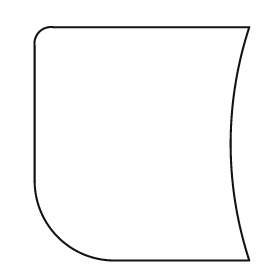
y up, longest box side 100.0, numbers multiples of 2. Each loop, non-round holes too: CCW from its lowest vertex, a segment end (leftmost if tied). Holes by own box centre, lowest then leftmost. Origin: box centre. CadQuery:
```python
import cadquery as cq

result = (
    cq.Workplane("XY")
    .moveTo(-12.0, -50.0)
    .lineTo(46.0, -50.0)
    .threePointArc((38.0, 0.0), (46.0, 50.0))
    .lineTo(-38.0, 50.0)
    .threePointArc((-44.0, 48.0), (-46.0, 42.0))
    .lineTo(-46.0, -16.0)
    .threePointArc((-36.0, -40.0), (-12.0, -50.0))
    .close()
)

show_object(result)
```